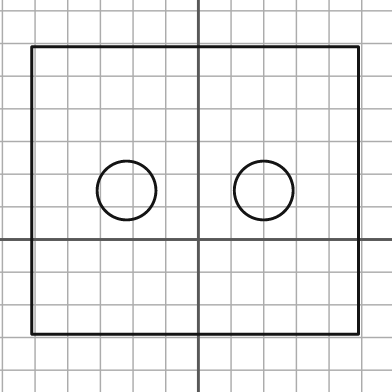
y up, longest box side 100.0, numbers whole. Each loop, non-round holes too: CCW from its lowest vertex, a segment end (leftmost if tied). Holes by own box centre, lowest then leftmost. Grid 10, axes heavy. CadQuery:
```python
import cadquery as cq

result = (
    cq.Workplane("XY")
    .moveTo(-51.0, -29.0)
    .lineTo(49.0, -29.0)
    .lineTo(49.0, 59.0)
    .lineTo(-51.0, 59.0)
    .close()
    .moveTo(-22.0, 15.0)
    .circle(9.0)
    .moveTo(20.0, 15.0)
    .circle(9.0)
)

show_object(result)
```